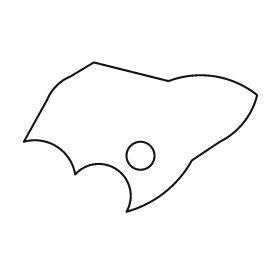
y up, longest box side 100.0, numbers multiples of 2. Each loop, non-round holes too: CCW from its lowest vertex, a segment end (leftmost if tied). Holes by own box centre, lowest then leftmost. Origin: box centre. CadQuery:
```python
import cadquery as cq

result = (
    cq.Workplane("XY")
    .moveTo(-6.0, -32.0)
    .threePointArc((10.0, -24.0), (22.0, -10.0))
    .lineTo(34.0, -2.0)
    .threePointArc((44.0, 6.0), (50.0, 18.0))
    .threePointArc((32.0, 26.0), (12.0, 24.0))
    .lineTo(-20.0, 32.0)
    .lineTo(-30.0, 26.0)
    .threePointArc((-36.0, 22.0), (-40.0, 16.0))
    .lineTo(-50.0, -2.0)
    .threePointArc((-36.0, -4.0), (-28.0, -16.0))
    .threePointArc((-10.0, -14.0), (-6.0, -32.0))
    .close()
    .moveTo(0.0, -8.0)
    .circle(6.0)
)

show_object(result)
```